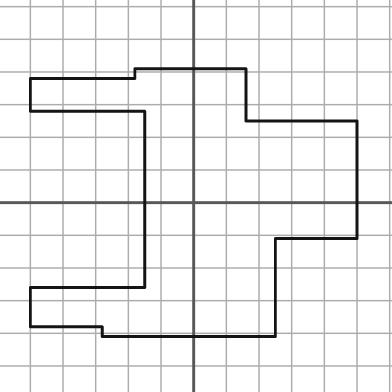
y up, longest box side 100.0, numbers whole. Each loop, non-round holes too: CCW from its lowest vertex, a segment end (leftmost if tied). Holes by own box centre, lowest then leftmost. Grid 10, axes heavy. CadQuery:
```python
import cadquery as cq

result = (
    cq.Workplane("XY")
    .moveTo(-28.0, -41.0)
    .lineTo(25.0, -41.0)
    .lineTo(25.0, -11.0)
    .lineTo(50.0, -11.0)
    .lineTo(50.0, 25.0)
    .lineTo(16.0, 25.0)
    .lineTo(16.0, 41.0)
    .lineTo(-18.0, 41.0)
    .lineTo(-18.0, 38.0)
    .lineTo(-50.0, 38.0)
    .lineTo(-50.0, 28.0)
    .lineTo(-15.0, 28.0)
    .lineTo(-15.0, -26.0)
    .lineTo(-50.0, -26.0)
    .lineTo(-50.0, -38.0)
    .lineTo(-28.0, -38.0)
    .close()
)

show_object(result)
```